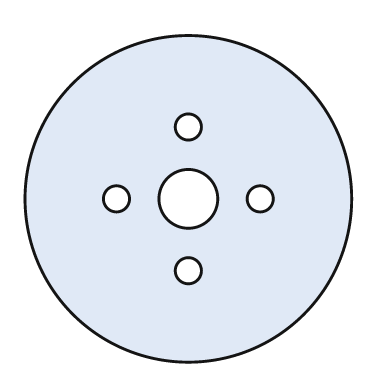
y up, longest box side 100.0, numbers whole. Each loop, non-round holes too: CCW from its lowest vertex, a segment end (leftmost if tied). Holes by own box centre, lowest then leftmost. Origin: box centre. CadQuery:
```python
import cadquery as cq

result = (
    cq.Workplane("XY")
    .moveTo(0.0, 0.0)
    .circle(50.0)
    .moveTo(0.0, -22.0)
    .circle(4.0)
    .moveTo(-22.0, 0.0)
    .circle(4.0)
    .moveTo(0.0, 0.0)
    .circle(9.0)
    .moveTo(22.0, 0.0)
    .circle(4.0)
    .moveTo(0.0, 22.0)
    .circle(4.0)
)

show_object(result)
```